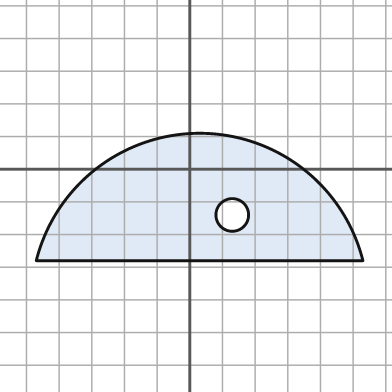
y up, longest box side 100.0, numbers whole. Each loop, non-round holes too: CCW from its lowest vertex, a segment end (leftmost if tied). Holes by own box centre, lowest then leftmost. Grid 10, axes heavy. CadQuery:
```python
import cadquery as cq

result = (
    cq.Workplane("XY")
    .moveTo(-47.0, -28.0)
    .lineTo(53.0, -28.0)
    .threePointArc((3.0, 11.0), (-47.0, -28.0))
    .close()
    .moveTo(13.0, -14.0)
    .circle(5.0)
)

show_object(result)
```